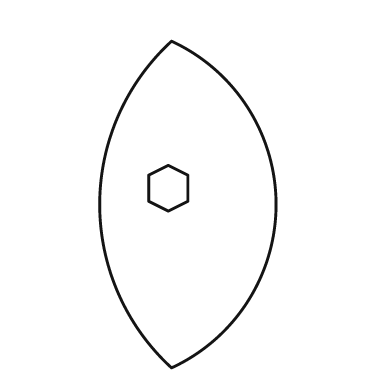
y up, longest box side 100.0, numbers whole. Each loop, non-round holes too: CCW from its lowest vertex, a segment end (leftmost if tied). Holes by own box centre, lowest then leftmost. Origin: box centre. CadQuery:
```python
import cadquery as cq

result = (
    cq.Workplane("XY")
    .moveTo(-5.0, -50.0)
    .threePointArc((27.0, 0.0), (-5.0, 50.0))
    .threePointArc((-27.0, 0.0), (-5.0, -50.0))
    .close()
    .moveTo(-6.0, -2.0)
    .lineTo(0.0, 1.0)
    .lineTo(0.0, 9.0)
    .lineTo(-6.0, 12.0)
    .lineTo(-12.0, 9.0)
    .lineTo(-12.0, 1.0)
    .close()
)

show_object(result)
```